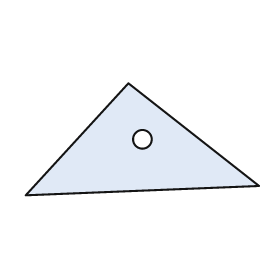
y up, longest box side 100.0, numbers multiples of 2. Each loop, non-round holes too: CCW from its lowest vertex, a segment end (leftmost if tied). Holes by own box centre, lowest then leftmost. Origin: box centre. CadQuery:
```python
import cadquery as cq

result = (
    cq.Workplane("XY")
    .moveTo(-50.0, -24.0)
    .lineTo(50.0, -20.0)
    .lineTo(-6.0, 24.0)
    .close()
    .moveTo(0.0, 0.0)
    .circle(4.0)
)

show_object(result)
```